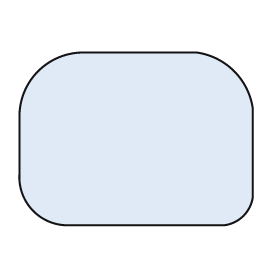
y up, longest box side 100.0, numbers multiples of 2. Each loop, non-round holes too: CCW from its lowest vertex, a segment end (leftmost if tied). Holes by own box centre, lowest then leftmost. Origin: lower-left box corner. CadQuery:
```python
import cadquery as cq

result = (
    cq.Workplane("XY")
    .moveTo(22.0, 0.0)
    .lineTo(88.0, 0.0)
    .threePointArc((96.0, 4.0), (100.0, 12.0))
    .lineTo(100.0, 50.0)
    .threePointArc((92.0, 66.0), (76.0, 74.0))
    .lineTo(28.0, 74.0)
    .threePointArc((8.0, 66.0), (0.0, 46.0))
    .lineTo(0.0, 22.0)
    .threePointArc((6.0, 6.0), (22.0, 0.0))
    .close()
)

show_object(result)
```